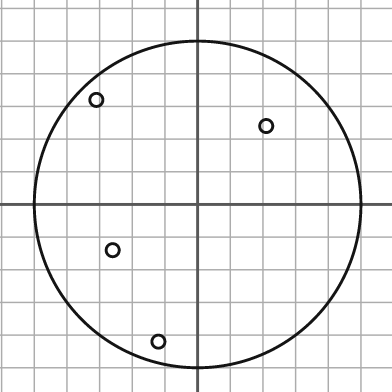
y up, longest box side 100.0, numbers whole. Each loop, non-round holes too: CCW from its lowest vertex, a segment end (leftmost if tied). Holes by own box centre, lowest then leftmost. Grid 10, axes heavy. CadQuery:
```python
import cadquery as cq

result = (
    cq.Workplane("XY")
    .moveTo(0.0, 0.0)
    .circle(50.0)
    .moveTo(-12.0, -42.0)
    .circle(2.0)
    .moveTo(-26.0, -14.0)
    .circle(2.0)
    .moveTo(21.0, 24.0)
    .circle(2.0)
    .moveTo(-31.0, 32.0)
    .circle(2.0)
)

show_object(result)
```